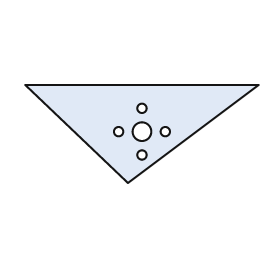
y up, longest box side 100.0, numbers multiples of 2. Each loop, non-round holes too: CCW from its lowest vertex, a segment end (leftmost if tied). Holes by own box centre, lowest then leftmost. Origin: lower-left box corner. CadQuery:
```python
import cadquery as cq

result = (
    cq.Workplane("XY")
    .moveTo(44.0, 0.0)
    .lineTo(100.0, 42.0)
    .lineTo(0.0, 42.0)
    .close()
    .moveTo(50.0, 12.0)
    .circle(2.0)
    .moveTo(40.0, 22.0)
    .circle(2.0)
    .moveTo(50.0, 22.0)
    .circle(4.0)
    .moveTo(60.0, 22.0)
    .circle(2.0)
    .moveTo(50.0, 32.0)
    .circle(2.0)
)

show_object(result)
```